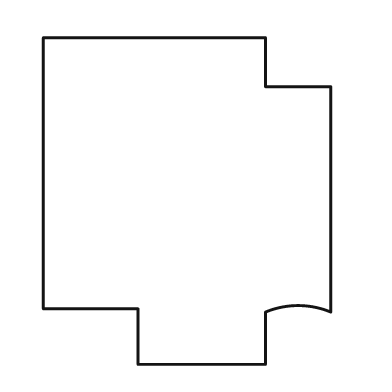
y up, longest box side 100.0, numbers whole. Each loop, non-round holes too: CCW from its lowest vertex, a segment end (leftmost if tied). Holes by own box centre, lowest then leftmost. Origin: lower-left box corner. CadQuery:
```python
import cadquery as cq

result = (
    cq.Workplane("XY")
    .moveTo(29.0, 0.0)
    .lineTo(68.0, 0.0)
    .lineTo(68.0, 16.0)
    .threePointArc((78.0, 18.0), (88.0, 16.0))
    .lineTo(88.0, 85.0)
    .lineTo(68.0, 85.0)
    .lineTo(68.0, 100.0)
    .lineTo(0.0, 100.0)
    .lineTo(0.0, 17.0)
    .lineTo(29.0, 17.0)
    .close()
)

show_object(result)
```